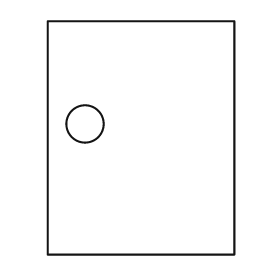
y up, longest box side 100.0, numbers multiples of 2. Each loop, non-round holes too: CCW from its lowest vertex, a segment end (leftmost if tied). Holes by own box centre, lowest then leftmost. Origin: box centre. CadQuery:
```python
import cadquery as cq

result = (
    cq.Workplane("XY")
    .moveTo(-40.0, -50.0)
    .lineTo(40.0, -50.0)
    .lineTo(40.0, 50.0)
    .lineTo(-40.0, 50.0)
    .close()
    .moveTo(-24.0, 6.0)
    .circle(8.0)
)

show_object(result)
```